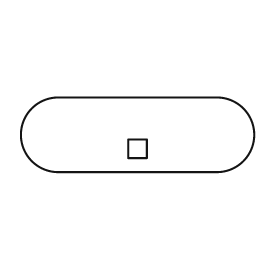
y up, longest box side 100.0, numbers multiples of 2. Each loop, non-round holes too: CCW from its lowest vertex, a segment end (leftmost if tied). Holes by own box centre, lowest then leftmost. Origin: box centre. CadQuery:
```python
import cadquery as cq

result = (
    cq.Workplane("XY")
    .moveTo(-34.0, -16.0)
    .lineTo(34.0, -16.0)
    .threePointArc((50.0, 0.0), (34.0, 16.0))
    .lineTo(-34.0, 16.0)
    .threePointArc((-50.0, 0.0), (-34.0, -16.0))
    .close()
    .moveTo(-4.0, -10.0)
    .lineTo(4.0, -10.0)
    .lineTo(4.0, -2.0)
    .lineTo(-4.0, -2.0)
    .close()
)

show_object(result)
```